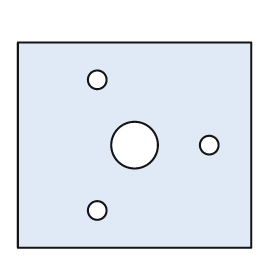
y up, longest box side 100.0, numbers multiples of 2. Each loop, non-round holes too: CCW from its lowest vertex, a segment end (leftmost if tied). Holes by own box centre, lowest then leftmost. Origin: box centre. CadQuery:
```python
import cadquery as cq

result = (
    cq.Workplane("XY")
    .moveTo(-50.0, -44.0)
    .lineTo(50.0, -44.0)
    .lineTo(50.0, 44.0)
    .lineTo(-50.0, 44.0)
    .close()
    .moveTo(-16.0, -28.0)
    .circle(4.0)
    .moveTo(0.0, 0.0)
    .circle(10.0)
    .moveTo(32.0, 0.0)
    .circle(4.0)
    .moveTo(-16.0, 28.0)
    .circle(4.0)
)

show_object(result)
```